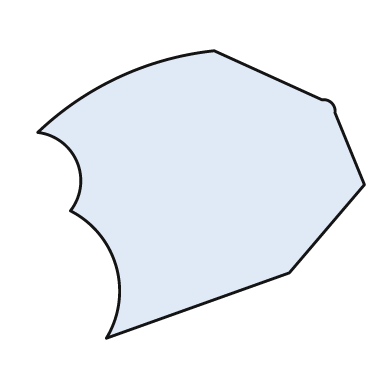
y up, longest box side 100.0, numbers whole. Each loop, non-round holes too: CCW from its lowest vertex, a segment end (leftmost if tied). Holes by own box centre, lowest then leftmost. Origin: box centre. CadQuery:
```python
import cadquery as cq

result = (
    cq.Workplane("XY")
    .moveTo(-29.0, -44.0)
    .lineTo(27.0, -24.0)
    .lineTo(50.0, 3.0)
    .lineTo(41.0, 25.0)
    .threePointArc((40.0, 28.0), (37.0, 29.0))
    .lineTo(4.0, 44.0)
    .threePointArc((-25.0, 36.0), (-50.0, 19.0))
    .threePointArc((-38.0, 10.0), (-40.0, -5.0))
    .threePointArc((-26.0, -22.0), (-29.0, -44.0))
    .close()
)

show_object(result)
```